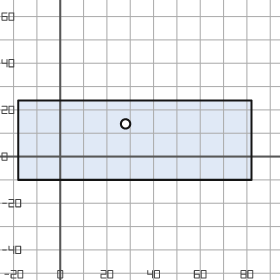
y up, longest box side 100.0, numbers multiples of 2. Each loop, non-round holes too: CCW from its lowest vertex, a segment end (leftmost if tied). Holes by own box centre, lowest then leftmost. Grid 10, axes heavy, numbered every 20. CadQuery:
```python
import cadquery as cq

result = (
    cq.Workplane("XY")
    .moveTo(-18.0, -10.0)
    .lineTo(82.0, -10.0)
    .lineTo(82.0, 24.0)
    .lineTo(-18.0, 24.0)
    .close()
    .moveTo(28.0, 14.0)
    .circle(2.0)
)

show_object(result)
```